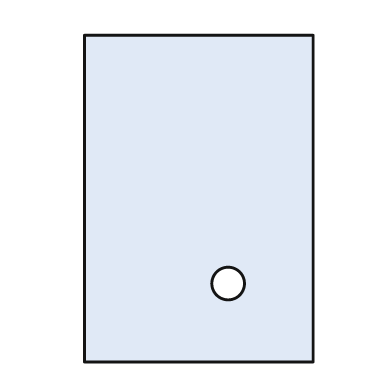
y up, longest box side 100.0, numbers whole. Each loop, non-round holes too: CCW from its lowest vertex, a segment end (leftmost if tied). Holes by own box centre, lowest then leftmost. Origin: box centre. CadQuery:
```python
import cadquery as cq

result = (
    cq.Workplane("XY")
    .moveTo(-35.0, -50.0)
    .lineTo(35.0, -50.0)
    .lineTo(35.0, 50.0)
    .lineTo(-35.0, 50.0)
    .close()
    .moveTo(9.0, -26.0)
    .circle(5.0)
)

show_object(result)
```